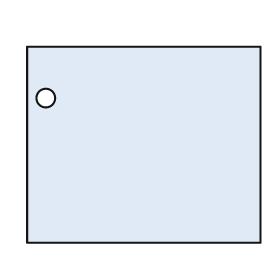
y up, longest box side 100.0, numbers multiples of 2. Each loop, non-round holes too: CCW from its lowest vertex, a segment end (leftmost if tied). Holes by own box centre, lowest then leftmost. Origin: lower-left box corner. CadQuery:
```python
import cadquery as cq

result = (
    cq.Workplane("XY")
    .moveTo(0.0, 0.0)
    .lineTo(100.0, 0.0)
    .lineTo(100.0, 84.0)
    .lineTo(0.0, 84.0)
    .close()
    .moveTo(8.0, 62.0)
    .circle(4.0)
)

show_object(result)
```